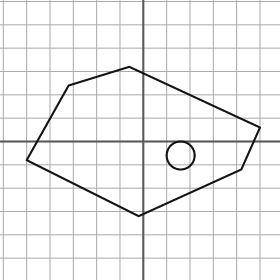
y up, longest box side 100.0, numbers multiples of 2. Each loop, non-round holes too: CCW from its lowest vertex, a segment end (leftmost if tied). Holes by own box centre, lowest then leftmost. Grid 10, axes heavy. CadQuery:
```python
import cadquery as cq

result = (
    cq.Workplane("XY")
    .moveTo(-2.0, -32.0)
    .lineTo(42.0, -12.0)
    .lineTo(50.0, 6.0)
    .lineTo(-6.0, 32.0)
    .lineTo(-32.0, 24.0)
    .lineTo(-50.0, -8.0)
    .close()
    .moveTo(16.0, -6.0)
    .circle(6.0)
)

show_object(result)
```